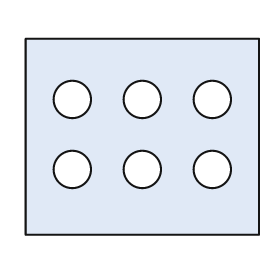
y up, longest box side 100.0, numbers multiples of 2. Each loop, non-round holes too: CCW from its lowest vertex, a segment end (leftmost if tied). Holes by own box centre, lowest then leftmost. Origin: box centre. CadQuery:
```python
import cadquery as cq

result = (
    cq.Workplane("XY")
    .moveTo(-50.0, -42.0)
    .lineTo(50.0, -42.0)
    .lineTo(50.0, 42.0)
    .lineTo(-50.0, 42.0)
    .close()
    .moveTo(-30.0, -14.0)
    .circle(8.0)
    .moveTo(0.0, -14.0)
    .circle(8.0)
    .moveTo(30.0, -14.0)
    .circle(8.0)
    .moveTo(-30.0, 16.0)
    .circle(8.0)
    .moveTo(0.0, 16.0)
    .circle(8.0)
    .moveTo(30.0, 16.0)
    .circle(8.0)
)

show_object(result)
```